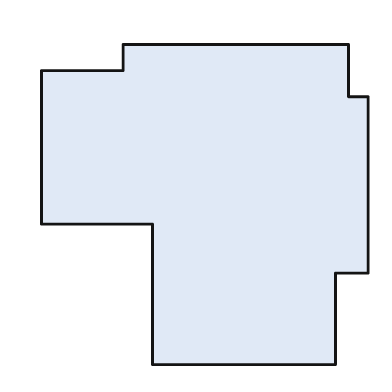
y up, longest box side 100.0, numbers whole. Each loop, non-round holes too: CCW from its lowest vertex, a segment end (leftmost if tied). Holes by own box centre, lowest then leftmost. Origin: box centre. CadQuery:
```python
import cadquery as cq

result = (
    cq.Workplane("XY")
    .moveTo(-16.0, -49.0)
    .lineTo(40.0, -49.0)
    .lineTo(40.0, -21.0)
    .lineTo(50.0, -21.0)
    .lineTo(50.0, 33.0)
    .lineTo(44.0, 33.0)
    .lineTo(44.0, 49.0)
    .lineTo(-25.0, 49.0)
    .lineTo(-25.0, 41.0)
    .lineTo(-50.0, 41.0)
    .lineTo(-50.0, -6.0)
    .lineTo(-16.0, -6.0)
    .close()
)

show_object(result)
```